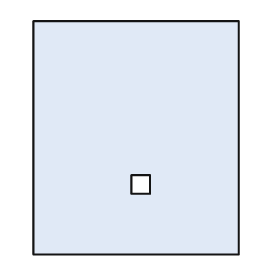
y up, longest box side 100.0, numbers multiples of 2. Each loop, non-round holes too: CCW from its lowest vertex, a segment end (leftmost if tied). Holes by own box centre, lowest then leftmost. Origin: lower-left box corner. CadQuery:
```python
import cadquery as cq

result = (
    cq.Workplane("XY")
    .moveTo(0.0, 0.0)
    .lineTo(88.0, 0.0)
    .lineTo(88.0, 100.0)
    .lineTo(0.0, 100.0)
    .close()
    .moveTo(42.0, 26.0)
    .lineTo(50.0, 26.0)
    .lineTo(50.0, 34.0)
    .lineTo(42.0, 34.0)
    .close()
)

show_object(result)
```